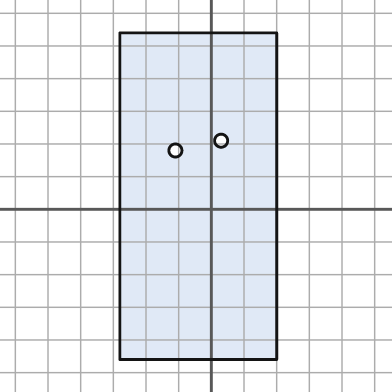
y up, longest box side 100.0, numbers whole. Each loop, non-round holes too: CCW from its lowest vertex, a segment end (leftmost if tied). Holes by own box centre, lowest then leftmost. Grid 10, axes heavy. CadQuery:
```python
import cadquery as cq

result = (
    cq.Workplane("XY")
    .moveTo(-28.0, -46.0)
    .lineTo(20.0, -46.0)
    .lineTo(20.0, 54.0)
    .lineTo(-28.0, 54.0)
    .close()
    .moveTo(-11.0, 18.0)
    .circle(2.0)
    .moveTo(3.0, 21.0)
    .circle(2.0)
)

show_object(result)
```